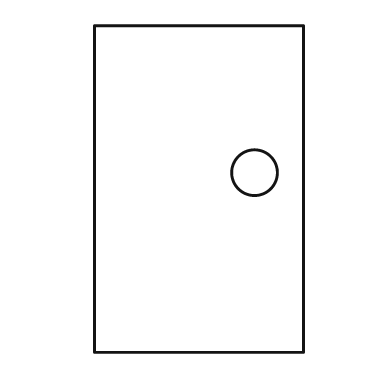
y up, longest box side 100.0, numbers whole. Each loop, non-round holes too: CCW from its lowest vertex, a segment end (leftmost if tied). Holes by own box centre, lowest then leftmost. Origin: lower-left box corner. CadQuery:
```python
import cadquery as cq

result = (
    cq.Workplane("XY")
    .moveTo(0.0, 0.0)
    .lineTo(64.0, 0.0)
    .lineTo(64.0, 100.0)
    .lineTo(0.0, 100.0)
    .close()
    .moveTo(49.0, 55.0)
    .circle(7.0)
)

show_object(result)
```